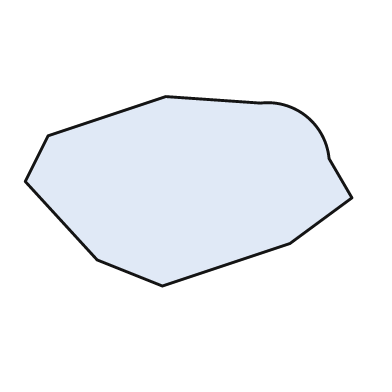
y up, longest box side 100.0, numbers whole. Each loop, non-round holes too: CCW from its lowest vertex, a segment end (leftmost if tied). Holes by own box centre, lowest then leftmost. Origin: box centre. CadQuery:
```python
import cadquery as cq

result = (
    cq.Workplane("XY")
    .moveTo(-8.0, -29.0)
    .lineTo(31.0, -16.0)
    .lineTo(50.0, -2.0)
    .lineTo(43.0, 10.0)
    .threePointArc((36.0, 23.0), (22.0, 27.0))
    .lineTo(-7.0, 29.0)
    .lineTo(-43.0, 17.0)
    .lineTo(-50.0, 3.0)
    .lineTo(-28.0, -21.0)
    .close()
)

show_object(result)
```